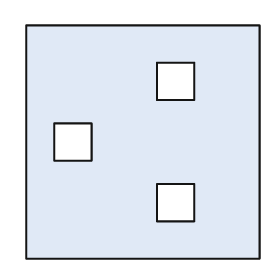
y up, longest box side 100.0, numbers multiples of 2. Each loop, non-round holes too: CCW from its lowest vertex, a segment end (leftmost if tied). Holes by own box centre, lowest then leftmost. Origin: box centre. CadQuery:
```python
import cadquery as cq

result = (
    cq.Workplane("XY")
    .moveTo(-50.0, -50.0)
    .lineTo(50.0, -50.0)
    .lineTo(50.0, 50.0)
    .lineTo(-50.0, 50.0)
    .close()
    .moveTo(6.0, -34.0)
    .lineTo(22.0, -34.0)
    .lineTo(22.0, -18.0)
    .lineTo(6.0, -18.0)
    .close()
    .moveTo(-38.0, -8.0)
    .lineTo(-22.0, -8.0)
    .lineTo(-22.0, 8.0)
    .lineTo(-38.0, 8.0)
    .close()
    .moveTo(6.0, 18.0)
    .lineTo(22.0, 18.0)
    .lineTo(22.0, 34.0)
    .lineTo(6.0, 34.0)
    .close()
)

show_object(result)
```